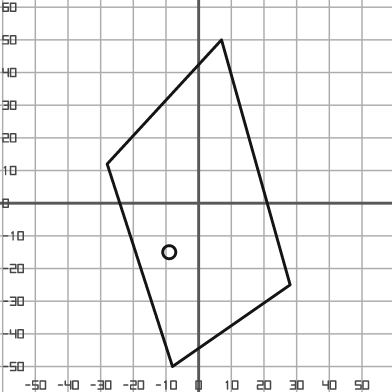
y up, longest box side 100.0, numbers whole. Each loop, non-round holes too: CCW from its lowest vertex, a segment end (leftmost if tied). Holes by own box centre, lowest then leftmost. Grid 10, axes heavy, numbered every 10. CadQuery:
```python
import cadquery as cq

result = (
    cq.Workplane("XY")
    .moveTo(-8.0, -50.0)
    .lineTo(28.0, -25.0)
    .lineTo(7.0, 50.0)
    .lineTo(-28.0, 12.0)
    .close()
    .moveTo(-9.0, -15.0)
    .circle(2.0)
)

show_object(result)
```